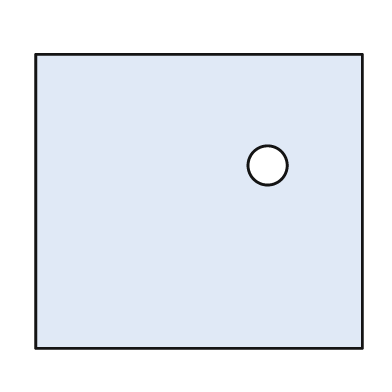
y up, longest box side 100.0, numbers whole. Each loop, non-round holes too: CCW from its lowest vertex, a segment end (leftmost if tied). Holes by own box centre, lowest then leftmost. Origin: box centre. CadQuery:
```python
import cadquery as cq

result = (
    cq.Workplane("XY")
    .moveTo(-50.0, -45.0)
    .lineTo(50.0, -45.0)
    .lineTo(50.0, 45.0)
    .lineTo(-50.0, 45.0)
    .close()
    .moveTo(21.0, 11.0)
    .circle(6.0)
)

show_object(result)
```